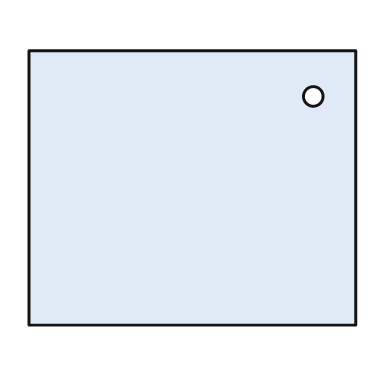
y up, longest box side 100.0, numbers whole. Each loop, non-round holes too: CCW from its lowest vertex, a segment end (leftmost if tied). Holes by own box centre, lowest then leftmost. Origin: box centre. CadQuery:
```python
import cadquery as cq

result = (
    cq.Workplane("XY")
    .moveTo(-50.0, -42.0)
    .lineTo(50.0, -42.0)
    .lineTo(50.0, 42.0)
    .lineTo(-50.0, 42.0)
    .close()
    .moveTo(37.0, 28.0)
    .circle(3.0)
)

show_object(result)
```